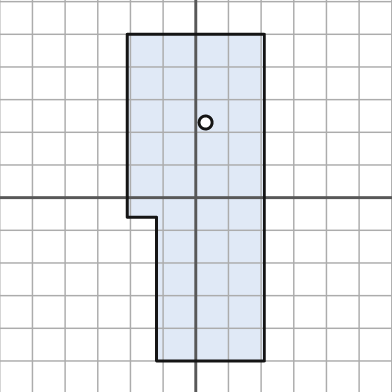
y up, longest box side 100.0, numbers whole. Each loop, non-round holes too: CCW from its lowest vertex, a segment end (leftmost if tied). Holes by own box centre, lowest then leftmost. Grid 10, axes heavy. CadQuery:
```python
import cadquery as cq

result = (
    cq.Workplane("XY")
    .moveTo(-12.0, -50.0)
    .lineTo(21.0, -50.0)
    .lineTo(21.0, 50.0)
    .lineTo(-21.0, 50.0)
    .lineTo(-21.0, -6.0)
    .lineTo(-12.0, -6.0)
    .close()
    .moveTo(3.0, 23.0)
    .circle(2.0)
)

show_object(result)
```